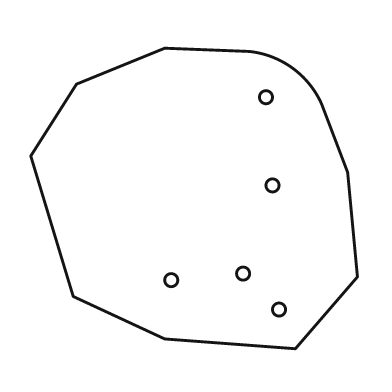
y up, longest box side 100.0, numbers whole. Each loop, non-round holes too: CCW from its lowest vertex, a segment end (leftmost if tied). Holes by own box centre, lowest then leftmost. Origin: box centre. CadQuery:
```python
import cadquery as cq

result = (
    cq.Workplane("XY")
    .moveTo(31.0, -46.0)
    .lineTo(50.0, -24.0)
    .lineTo(47.0, 8.0)
    .lineTo(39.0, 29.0)
    .threePointArc((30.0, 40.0), (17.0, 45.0))
    .lineTo(-9.0, 46.0)
    .lineTo(-36.0, 35.0)
    .lineTo(-50.0, 13.0)
    .lineTo(-37.0, -30.0)
    .lineTo(-9.0, -43.0)
    .close()
    .moveTo(26.0, -34.0)
    .circle(2.0)
    .moveTo(-7.0, -25.0)
    .circle(2.0)
    .moveTo(15.0, -23.0)
    .circle(2.0)
    .moveTo(24.0, 4.0)
    .circle(2.0)
    .moveTo(22.0, 31.0)
    .circle(2.0)
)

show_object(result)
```